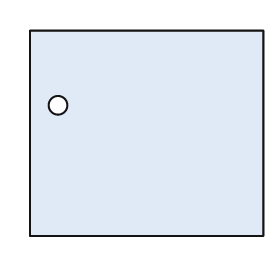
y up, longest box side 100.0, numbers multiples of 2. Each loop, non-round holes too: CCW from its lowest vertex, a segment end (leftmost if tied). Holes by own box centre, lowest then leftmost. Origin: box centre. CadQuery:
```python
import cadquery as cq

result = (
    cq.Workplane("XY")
    .moveTo(-50.0, -44.0)
    .lineTo(50.0, -44.0)
    .lineTo(50.0, 44.0)
    .lineTo(-50.0, 44.0)
    .close()
    .moveTo(-38.0, 12.0)
    .circle(4.0)
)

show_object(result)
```